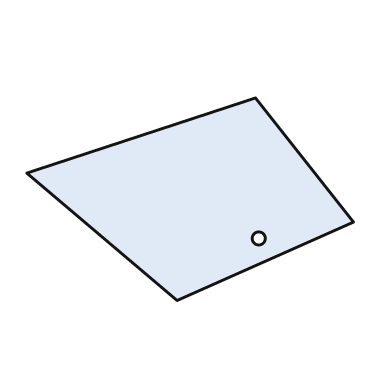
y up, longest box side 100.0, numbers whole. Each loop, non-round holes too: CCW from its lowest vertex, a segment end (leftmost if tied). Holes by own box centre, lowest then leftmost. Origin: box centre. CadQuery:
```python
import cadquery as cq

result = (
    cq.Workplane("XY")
    .moveTo(-4.0, -31.0)
    .lineTo(50.0, -7.0)
    .lineTo(20.0, 31.0)
    .lineTo(-50.0, 8.0)
    .close()
    .moveTo(21.0, -12.0)
    .circle(2.0)
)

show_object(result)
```